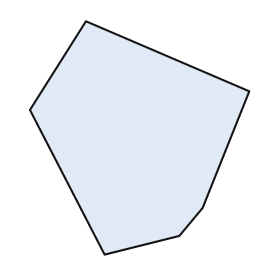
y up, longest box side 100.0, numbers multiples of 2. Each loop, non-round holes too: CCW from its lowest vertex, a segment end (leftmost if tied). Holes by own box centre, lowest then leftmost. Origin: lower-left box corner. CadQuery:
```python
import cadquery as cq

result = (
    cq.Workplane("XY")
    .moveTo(32.0, 0.0)
    .lineTo(64.0, 8.0)
    .lineTo(74.0, 20.0)
    .lineTo(94.0, 70.0)
    .lineTo(24.0, 100.0)
    .lineTo(0.0, 62.0)
    .close()
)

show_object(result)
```